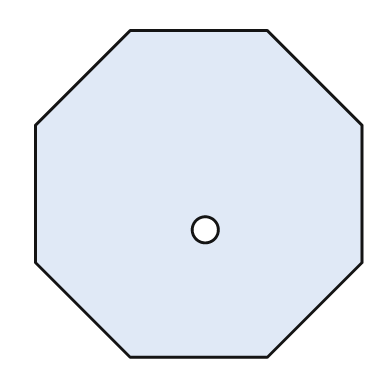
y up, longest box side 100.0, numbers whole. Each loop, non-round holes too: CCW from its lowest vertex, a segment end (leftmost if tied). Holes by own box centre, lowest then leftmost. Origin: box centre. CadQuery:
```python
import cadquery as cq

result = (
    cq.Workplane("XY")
    .moveTo(-21.0, -50.0)
    .lineTo(21.0, -50.0)
    .lineTo(50.0, -21.0)
    .lineTo(50.0, 21.0)
    .lineTo(21.0, 50.0)
    .lineTo(-21.0, 50.0)
    .lineTo(-50.0, 21.0)
    .lineTo(-50.0, -21.0)
    .close()
    .moveTo(2.0, -11.0)
    .circle(4.0)
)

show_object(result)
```